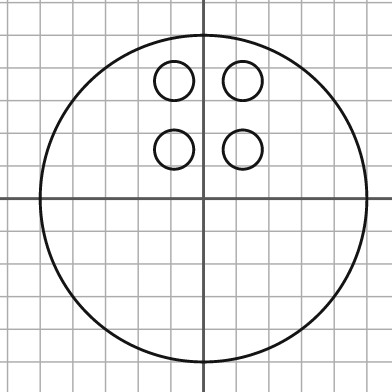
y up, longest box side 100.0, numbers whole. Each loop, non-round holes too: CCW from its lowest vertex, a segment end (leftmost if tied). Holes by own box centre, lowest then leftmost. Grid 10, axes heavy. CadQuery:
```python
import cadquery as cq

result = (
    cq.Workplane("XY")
    .moveTo(0.0, 0.0)
    .circle(50.0)
    .moveTo(-9.0, 15.0)
    .circle(6.0)
    .moveTo(12.0, 15.0)
    .circle(6.0)
    .moveTo(-9.0, 36.0)
    .circle(6.0)
    .moveTo(12.0, 36.0)
    .circle(6.0)
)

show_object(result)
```